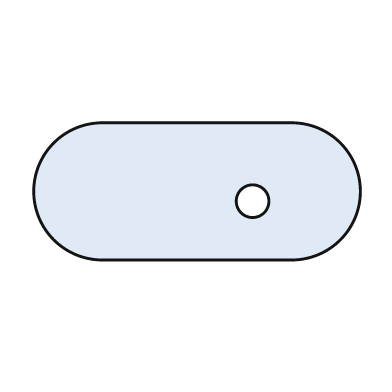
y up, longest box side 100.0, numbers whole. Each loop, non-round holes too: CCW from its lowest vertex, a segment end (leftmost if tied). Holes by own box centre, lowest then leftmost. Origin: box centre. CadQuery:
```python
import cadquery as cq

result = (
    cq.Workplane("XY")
    .moveTo(-29.0, -21.0)
    .lineTo(29.0, -21.0)
    .threePointArc((50.0, 0.0), (29.0, 21.0))
    .lineTo(-29.0, 21.0)
    .threePointArc((-50.0, 0.0), (-29.0, -21.0))
    .close()
    .moveTo(17.0, -3.0)
    .circle(5.0)
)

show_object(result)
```